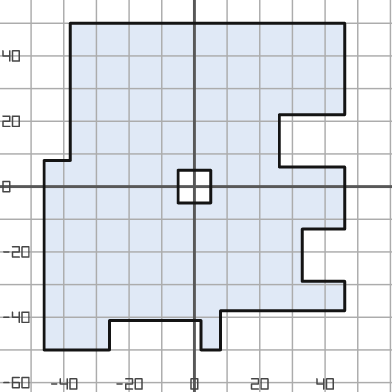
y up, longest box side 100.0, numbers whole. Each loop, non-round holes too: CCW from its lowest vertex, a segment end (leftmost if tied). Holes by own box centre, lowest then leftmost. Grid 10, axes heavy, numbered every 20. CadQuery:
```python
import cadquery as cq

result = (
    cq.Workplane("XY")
    .moveTo(-46.0, -50.0)
    .lineTo(-26.0, -50.0)
    .lineTo(-26.0, -41.0)
    .lineTo(2.0, -41.0)
    .lineTo(2.0, -50.0)
    .lineTo(8.0, -50.0)
    .lineTo(8.0, -38.0)
    .lineTo(46.0, -38.0)
    .lineTo(46.0, -29.0)
    .lineTo(33.0, -29.0)
    .lineTo(33.0, -13.0)
    .lineTo(46.0, -13.0)
    .lineTo(46.0, 6.0)
    .lineTo(26.0, 6.0)
    .lineTo(26.0, 22.0)
    .lineTo(46.0, 22.0)
    .lineTo(46.0, 50.0)
    .lineTo(-38.0, 50.0)
    .lineTo(-38.0, 8.0)
    .lineTo(-46.0, 8.0)
    .close()
    .moveTo(-5.0, -5.0)
    .lineTo(5.0, -5.0)
    .lineTo(5.0, 5.0)
    .lineTo(-5.0, 5.0)
    .close()
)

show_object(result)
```